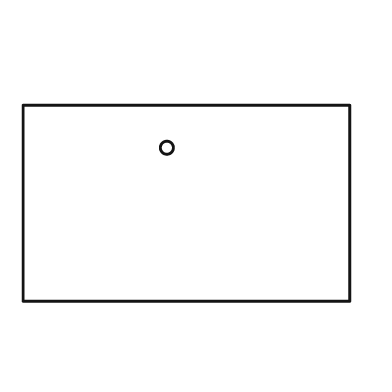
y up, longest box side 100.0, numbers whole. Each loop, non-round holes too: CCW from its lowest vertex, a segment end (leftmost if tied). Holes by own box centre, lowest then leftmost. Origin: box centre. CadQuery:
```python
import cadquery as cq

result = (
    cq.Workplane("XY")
    .moveTo(-50.0, -30.0)
    .lineTo(50.0, -30.0)
    .lineTo(50.0, 30.0)
    .lineTo(-50.0, 30.0)
    .close()
    .moveTo(-6.0, 17.0)
    .circle(2.0)
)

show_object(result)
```